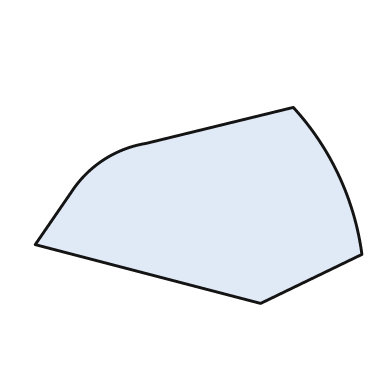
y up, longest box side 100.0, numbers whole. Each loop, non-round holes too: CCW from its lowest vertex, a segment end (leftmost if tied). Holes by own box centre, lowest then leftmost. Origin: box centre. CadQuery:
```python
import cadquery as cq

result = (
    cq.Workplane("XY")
    .moveTo(19.0, -30.0)
    .lineTo(50.0, -15.0)
    .threePointArc((43.0, 9.0), (29.0, 30.0))
    .lineTo(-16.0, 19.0)
    .threePointArc((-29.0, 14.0), (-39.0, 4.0))
    .lineTo(-50.0, -12.0)
    .close()
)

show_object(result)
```